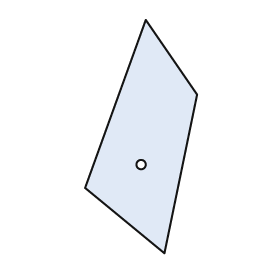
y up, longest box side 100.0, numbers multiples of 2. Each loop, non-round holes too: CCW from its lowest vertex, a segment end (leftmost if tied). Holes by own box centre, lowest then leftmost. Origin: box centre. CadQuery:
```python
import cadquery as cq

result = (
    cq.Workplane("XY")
    .moveTo(10.0, -50.0)
    .lineTo(24.0, 18.0)
    .lineTo(2.0, 50.0)
    .lineTo(-24.0, -22.0)
    .close()
    .moveTo(0.0, -12.0)
    .circle(2.0)
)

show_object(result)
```